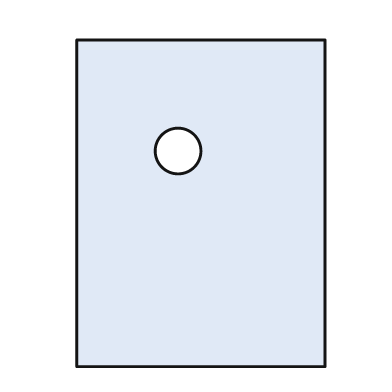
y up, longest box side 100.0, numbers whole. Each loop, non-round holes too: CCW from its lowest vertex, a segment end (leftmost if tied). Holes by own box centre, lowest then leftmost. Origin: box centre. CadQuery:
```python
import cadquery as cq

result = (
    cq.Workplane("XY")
    .moveTo(-38.0, -50.0)
    .lineTo(38.0, -50.0)
    .lineTo(38.0, 50.0)
    .lineTo(-38.0, 50.0)
    .close()
    .moveTo(-7.0, 16.0)
    .circle(7.0)
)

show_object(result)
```